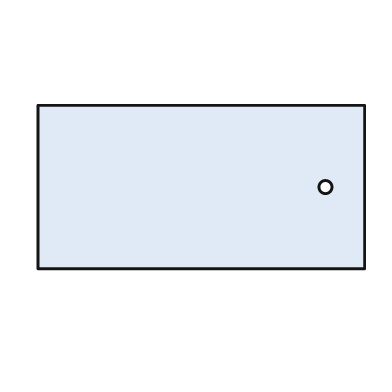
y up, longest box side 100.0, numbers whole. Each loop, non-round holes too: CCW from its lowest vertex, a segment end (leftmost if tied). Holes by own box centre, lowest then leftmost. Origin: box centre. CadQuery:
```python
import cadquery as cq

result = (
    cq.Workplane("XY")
    .moveTo(-50.0, -25.0)
    .lineTo(50.0, -25.0)
    .lineTo(50.0, 25.0)
    .lineTo(-50.0, 25.0)
    .close()
    .moveTo(38.0, 0.0)
    .circle(2.0)
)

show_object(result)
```